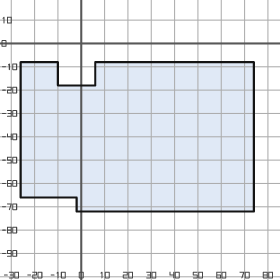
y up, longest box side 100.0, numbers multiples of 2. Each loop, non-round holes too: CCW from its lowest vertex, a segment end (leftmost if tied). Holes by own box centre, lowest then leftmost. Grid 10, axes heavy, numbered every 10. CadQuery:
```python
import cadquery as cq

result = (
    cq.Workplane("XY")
    .moveTo(-2.0, -72.0)
    .lineTo(74.0, -72.0)
    .lineTo(74.0, -8.0)
    .lineTo(6.0, -8.0)
    .lineTo(6.0, -18.0)
    .lineTo(-10.0, -18.0)
    .lineTo(-10.0, -8.0)
    .lineTo(-26.0, -8.0)
    .lineTo(-26.0, -66.0)
    .lineTo(-2.0, -66.0)
    .close()
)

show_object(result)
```